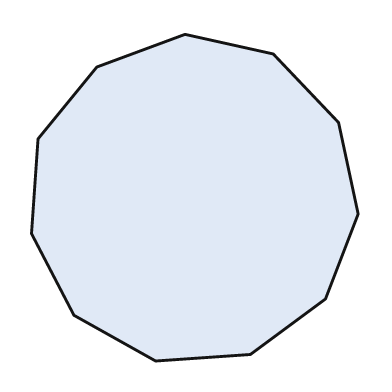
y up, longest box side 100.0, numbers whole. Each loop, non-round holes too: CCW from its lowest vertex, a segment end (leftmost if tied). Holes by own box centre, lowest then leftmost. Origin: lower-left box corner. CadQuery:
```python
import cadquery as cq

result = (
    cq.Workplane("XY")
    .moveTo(38.0, 0.0)
    .lineTo(67.0, 2.0)
    .lineTo(90.0, 19.0)
    .lineTo(100.0, 45.0)
    .lineTo(94.0, 73.0)
    .lineTo(74.0, 94.0)
    .lineTo(47.0, 100.0)
    .lineTo(20.0, 90.0)
    .lineTo(2.0, 68.0)
    .lineTo(0.0, 39.0)
    .lineTo(13.0, 14.0)
    .close()
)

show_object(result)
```